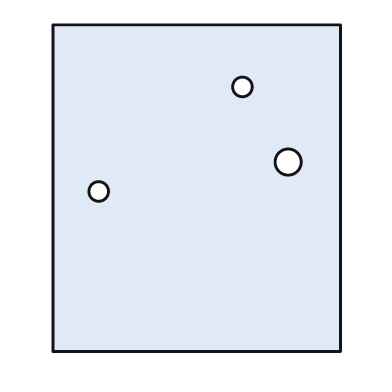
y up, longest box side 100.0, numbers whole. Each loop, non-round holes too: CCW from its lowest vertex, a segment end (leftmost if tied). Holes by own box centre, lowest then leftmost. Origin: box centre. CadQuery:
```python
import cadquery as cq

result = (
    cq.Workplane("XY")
    .moveTo(-44.0, -50.0)
    .lineTo(44.0, -50.0)
    .lineTo(44.0, 50.0)
    .lineTo(-44.0, 50.0)
    .close()
    .moveTo(-30.0, -1.0)
    .circle(3.0)
    .moveTo(28.0, 8.0)
    .circle(4.0)
    .moveTo(14.0, 31.0)
    .circle(3.0)
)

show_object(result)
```